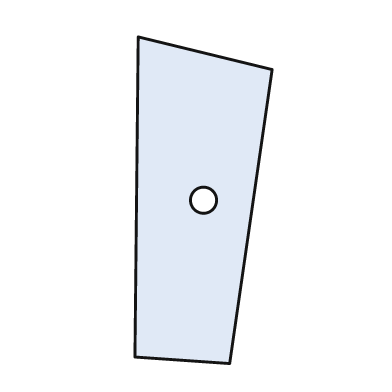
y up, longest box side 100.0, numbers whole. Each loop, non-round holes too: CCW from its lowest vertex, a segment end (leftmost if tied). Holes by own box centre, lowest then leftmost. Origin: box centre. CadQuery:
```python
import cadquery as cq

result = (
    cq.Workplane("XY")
    .moveTo(8.0, -50.0)
    .lineTo(21.0, 40.0)
    .lineTo(-20.0, 50.0)
    .lineTo(-21.0, -48.0)
    .close()
    .moveTo(0.0, 0.0)
    .circle(4.0)
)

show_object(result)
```